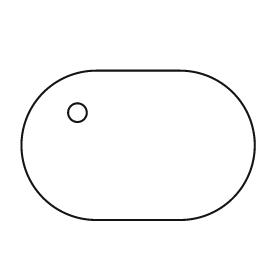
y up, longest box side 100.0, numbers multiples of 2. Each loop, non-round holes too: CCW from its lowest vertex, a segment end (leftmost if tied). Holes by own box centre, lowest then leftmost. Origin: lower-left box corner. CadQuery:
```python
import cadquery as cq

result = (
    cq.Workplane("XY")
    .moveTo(32.0, 0.0)
    .lineTo(68.0, 0.0)
    .threePointArc((100.0, 32.0), (68.0, 64.0))
    .lineTo(32.0, 64.0)
    .threePointArc((0.0, 32.0), (32.0, 0.0))
    .close()
    .moveTo(24.0, 46.0)
    .circle(4.0)
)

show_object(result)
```